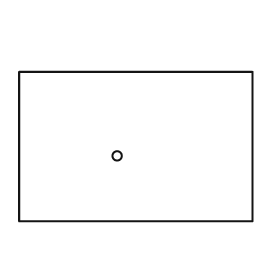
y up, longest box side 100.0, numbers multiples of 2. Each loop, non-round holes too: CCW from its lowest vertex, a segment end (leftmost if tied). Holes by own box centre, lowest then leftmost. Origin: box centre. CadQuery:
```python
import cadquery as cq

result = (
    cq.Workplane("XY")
    .moveTo(-50.0, -32.0)
    .lineTo(50.0, -32.0)
    .lineTo(50.0, 32.0)
    .lineTo(-50.0, 32.0)
    .close()
    .moveTo(-8.0, -4.0)
    .circle(2.0)
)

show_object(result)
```